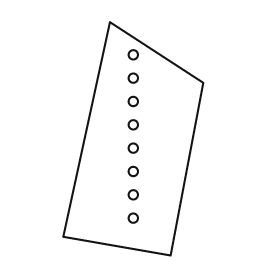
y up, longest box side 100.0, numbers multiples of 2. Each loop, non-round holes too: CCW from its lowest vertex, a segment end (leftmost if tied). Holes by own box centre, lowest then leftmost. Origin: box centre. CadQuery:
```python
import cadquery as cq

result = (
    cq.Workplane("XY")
    .moveTo(16.0, -50.0)
    .lineTo(30.0, 24.0)
    .lineTo(-10.0, 50.0)
    .lineTo(-30.0, -42.0)
    .close()
    .moveTo(0.0, -34.0)
    .circle(2.0)
    .moveTo(0.0, -24.0)
    .circle(2.0)
    .moveTo(0.0, -14.0)
    .circle(2.0)
    .moveTo(0.0, -4.0)
    .circle(2.0)
    .moveTo(0.0, 6.0)
    .circle(2.0)
    .moveTo(0.0, 16.0)
    .circle(2.0)
    .moveTo(0.0, 26.0)
    .circle(2.0)
    .moveTo(0.0, 36.0)
    .circle(2.0)
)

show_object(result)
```